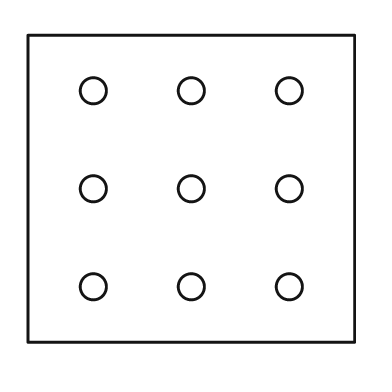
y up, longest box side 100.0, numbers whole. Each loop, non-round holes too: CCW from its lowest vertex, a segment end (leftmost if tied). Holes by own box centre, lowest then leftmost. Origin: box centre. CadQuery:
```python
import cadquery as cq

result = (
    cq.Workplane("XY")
    .moveTo(-50.0, -47.0)
    .lineTo(50.0, -47.0)
    .lineTo(50.0, 47.0)
    .lineTo(-50.0, 47.0)
    .close()
    .moveTo(-30.0, -30.0)
    .circle(4.0)
    .moveTo(0.0, -30.0)
    .circle(4.0)
    .moveTo(30.0, -30.0)
    .circle(4.0)
    .moveTo(-30.0, 0.0)
    .circle(4.0)
    .moveTo(0.0, 0.0)
    .circle(4.0)
    .moveTo(30.0, 0.0)
    .circle(4.0)
    .moveTo(-30.0, 30.0)
    .circle(4.0)
    .moveTo(0.0, 30.0)
    .circle(4.0)
    .moveTo(30.0, 30.0)
    .circle(4.0)
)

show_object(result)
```